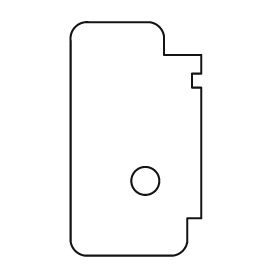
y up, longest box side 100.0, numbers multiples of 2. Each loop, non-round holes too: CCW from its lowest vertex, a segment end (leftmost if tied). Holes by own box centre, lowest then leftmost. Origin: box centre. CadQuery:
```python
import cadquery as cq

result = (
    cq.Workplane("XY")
    .moveTo(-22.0, -50.0)
    .lineTo(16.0, -50.0)
    .threePointArc((20.0, -48.0), (22.0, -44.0))
    .lineTo(22.0, -34.0)
    .lineTo(28.0, -34.0)
    .lineTo(28.0, 22.0)
    .lineTo(24.0, 22.0)
    .lineTo(24.0, 28.0)
    .lineTo(28.0, 28.0)
    .lineTo(28.0, 36.0)
    .lineTo(12.0, 36.0)
    .lineTo(12.0, 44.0)
    .threePointArc((10.0, 48.0), (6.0, 50.0))
    .lineTo(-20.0, 50.0)
    .threePointArc((-26.0, 48.0), (-28.0, 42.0))
    .lineTo(-28.0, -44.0)
    .threePointArc((-26.0, -48.0), (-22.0, -50.0))
    .close()
    .moveTo(4.0, -18.0)
    .circle(6.0)
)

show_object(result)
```